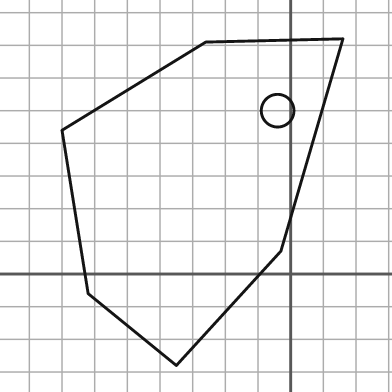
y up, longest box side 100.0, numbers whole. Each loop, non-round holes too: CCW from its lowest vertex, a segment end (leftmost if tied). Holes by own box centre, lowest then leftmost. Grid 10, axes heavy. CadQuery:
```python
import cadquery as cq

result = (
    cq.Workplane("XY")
    .moveTo(-35.0, -28.0)
    .lineTo(-3.0, 7.0)
    .lineTo(16.0, 72.0)
    .lineTo(-26.0, 71.0)
    .lineTo(-70.0, 44.0)
    .lineTo(-62.0, -6.0)
    .close()
    .moveTo(-4.0, 50.0)
    .circle(5.0)
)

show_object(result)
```